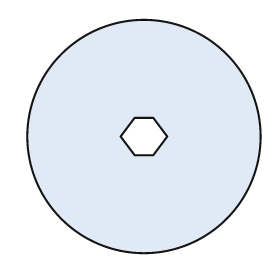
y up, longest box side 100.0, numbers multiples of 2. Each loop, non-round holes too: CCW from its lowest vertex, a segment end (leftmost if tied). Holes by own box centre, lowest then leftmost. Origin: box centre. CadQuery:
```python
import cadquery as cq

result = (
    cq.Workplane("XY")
    .moveTo(0.0, 0.0)
    .circle(50.0)
    .moveTo(-4.0, -8.0)
    .lineTo(4.0, -8.0)
    .lineTo(10.0, 0.0)
    .lineTo(4.0, 8.0)
    .lineTo(-4.0, 8.0)
    .lineTo(-10.0, 0.0)
    .close()
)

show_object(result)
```